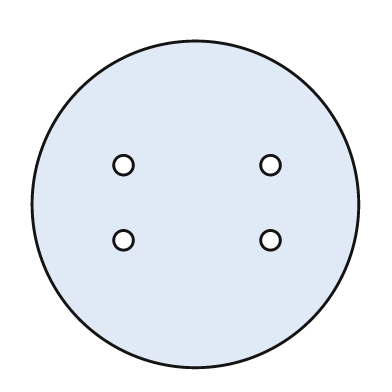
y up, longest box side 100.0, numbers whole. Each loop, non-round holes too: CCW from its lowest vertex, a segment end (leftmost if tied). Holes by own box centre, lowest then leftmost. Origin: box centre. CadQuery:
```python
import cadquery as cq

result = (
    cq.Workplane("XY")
    .moveTo(0.0, 0.0)
    .circle(50.0)
    .moveTo(-22.0, -11.0)
    .circle(3.0)
    .moveTo(23.0, -11.0)
    .circle(3.0)
    .moveTo(-22.0, 12.0)
    .circle(3.0)
    .moveTo(23.0, 12.0)
    .circle(3.0)
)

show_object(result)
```